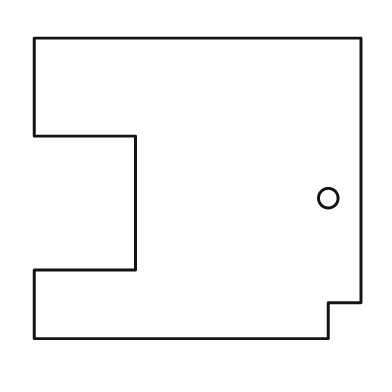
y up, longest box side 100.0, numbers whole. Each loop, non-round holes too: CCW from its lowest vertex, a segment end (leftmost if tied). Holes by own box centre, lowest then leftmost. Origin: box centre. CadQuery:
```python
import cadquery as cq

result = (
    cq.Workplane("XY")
    .moveTo(-50.0, -46.0)
    .lineTo(40.0, -46.0)
    .lineTo(40.0, -35.0)
    .lineTo(50.0, -35.0)
    .lineTo(50.0, 46.0)
    .lineTo(-50.0, 46.0)
    .lineTo(-50.0, 16.0)
    .lineTo(-19.0, 16.0)
    .lineTo(-19.0, -25.0)
    .lineTo(-50.0, -25.0)
    .close()
    .moveTo(40.0, -3.0)
    .circle(3.0)
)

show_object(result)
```